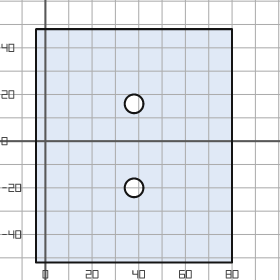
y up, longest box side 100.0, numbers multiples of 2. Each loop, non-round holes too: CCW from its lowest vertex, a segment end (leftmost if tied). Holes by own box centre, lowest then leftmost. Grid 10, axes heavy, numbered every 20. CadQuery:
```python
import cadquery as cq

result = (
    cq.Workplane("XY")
    .moveTo(-4.0, -52.0)
    .lineTo(80.0, -52.0)
    .lineTo(80.0, 48.0)
    .lineTo(-4.0, 48.0)
    .close()
    .moveTo(38.0, -20.0)
    .circle(4.0)
    .moveTo(38.0, 16.0)
    .circle(4.0)
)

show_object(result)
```